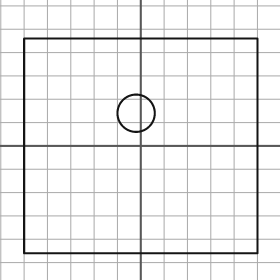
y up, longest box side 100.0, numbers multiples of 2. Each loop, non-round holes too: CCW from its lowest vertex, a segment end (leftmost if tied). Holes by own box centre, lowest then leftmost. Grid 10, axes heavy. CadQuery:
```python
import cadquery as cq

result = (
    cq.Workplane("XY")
    .moveTo(-50.0, -46.0)
    .lineTo(50.0, -46.0)
    .lineTo(50.0, 46.0)
    .lineTo(-50.0, 46.0)
    .close()
    .moveTo(-2.0, 14.0)
    .circle(8.0)
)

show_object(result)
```